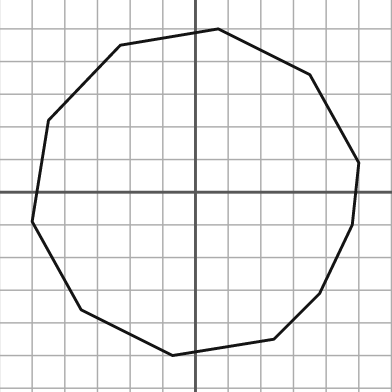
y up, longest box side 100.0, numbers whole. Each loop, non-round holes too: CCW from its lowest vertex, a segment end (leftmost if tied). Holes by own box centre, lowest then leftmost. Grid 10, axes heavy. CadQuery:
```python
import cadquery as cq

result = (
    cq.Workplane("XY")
    .moveTo(-7.0, -50.0)
    .lineTo(24.0, -45.0)
    .lineTo(38.0, -31.0)
    .lineTo(48.0, -10.0)
    .lineTo(50.0, 9.0)
    .lineTo(35.0, 36.0)
    .lineTo(7.0, 50.0)
    .lineTo(-23.0, 45.0)
    .lineTo(-45.0, 22.0)
    .lineTo(-50.0, -9.0)
    .lineTo(-35.0, -36.0)
    .close()
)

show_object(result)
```